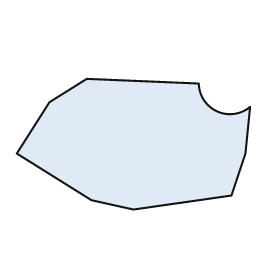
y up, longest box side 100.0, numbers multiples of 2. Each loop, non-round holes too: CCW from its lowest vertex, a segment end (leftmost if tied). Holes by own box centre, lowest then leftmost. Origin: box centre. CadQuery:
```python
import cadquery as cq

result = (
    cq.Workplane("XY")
    .moveTo(0.0, -28.0)
    .lineTo(42.0, -22.0)
    .lineTo(48.0, -4.0)
    .lineTo(50.0, 16.0)
    .threePointArc((36.0, 14.0), (28.0, 26.0))
    .lineTo(-20.0, 28.0)
    .lineTo(-36.0, 18.0)
    .lineTo(-50.0, -4.0)
    .lineTo(-18.0, -24.0)
    .close()
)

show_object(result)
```